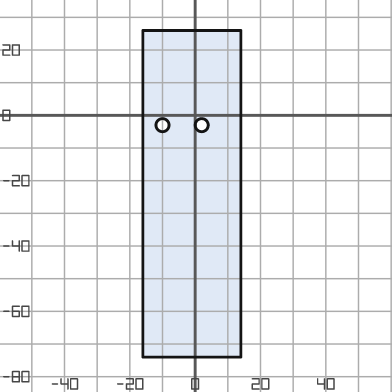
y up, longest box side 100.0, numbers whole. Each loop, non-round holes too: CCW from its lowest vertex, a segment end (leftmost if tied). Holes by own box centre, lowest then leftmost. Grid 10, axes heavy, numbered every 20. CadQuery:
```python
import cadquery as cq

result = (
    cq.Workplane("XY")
    .moveTo(-16.0, -74.0)
    .lineTo(14.0, -74.0)
    .lineTo(14.0, 26.0)
    .lineTo(-16.0, 26.0)
    .close()
    .moveTo(-10.0, -3.0)
    .circle(2.0)
    .moveTo(2.0, -3.0)
    .circle(2.0)
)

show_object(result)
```